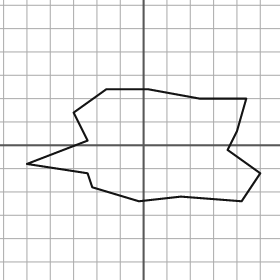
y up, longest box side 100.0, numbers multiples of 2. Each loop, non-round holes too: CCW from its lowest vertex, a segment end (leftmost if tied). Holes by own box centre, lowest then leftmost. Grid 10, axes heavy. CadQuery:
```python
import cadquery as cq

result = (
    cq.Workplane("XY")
    .moveTo(-2.0, -24.0)
    .lineTo(16.0, -22.0)
    .lineTo(42.0, -24.0)
    .lineTo(50.0, -12.0)
    .lineTo(36.0, -2.0)
    .lineTo(40.0, 6.0)
    .lineTo(44.0, 20.0)
    .lineTo(24.0, 20.0)
    .lineTo(2.0, 24.0)
    .lineTo(-16.0, 24.0)
    .lineTo(-30.0, 14.0)
    .lineTo(-24.0, 2.0)
    .lineTo(-50.0, -8.0)
    .lineTo(-24.0, -12.0)
    .lineTo(-22.0, -18.0)
    .close()
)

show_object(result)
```